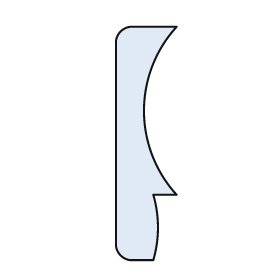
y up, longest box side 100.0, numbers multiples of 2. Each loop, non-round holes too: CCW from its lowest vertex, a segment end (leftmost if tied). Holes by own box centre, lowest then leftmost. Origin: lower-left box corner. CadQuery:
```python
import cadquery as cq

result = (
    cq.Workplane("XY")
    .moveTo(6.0, 0.0)
    .lineTo(16.0, 0.0)
    .threePointArc((18.0, 14.0), (16.0, 28.0))
    .lineTo(26.0, 28.0)
    .threePointArc((12.0, 64.0), (26.0, 100.0))
    .lineTo(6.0, 100.0)
    .threePointArc((2.0, 98.0), (0.0, 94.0))
    .lineTo(0.0, 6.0)
    .threePointArc((2.0, 2.0), (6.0, 0.0))
    .close()
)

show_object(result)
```